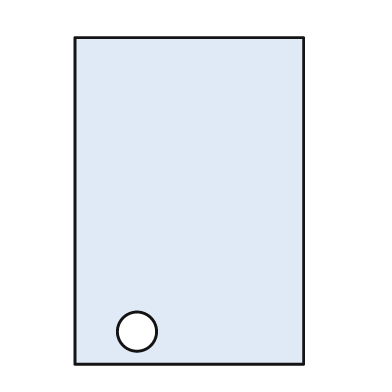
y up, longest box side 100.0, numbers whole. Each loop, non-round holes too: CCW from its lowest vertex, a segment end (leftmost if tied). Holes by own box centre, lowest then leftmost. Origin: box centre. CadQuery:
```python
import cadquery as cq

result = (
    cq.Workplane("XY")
    .moveTo(-35.0, -50.0)
    .lineTo(35.0, -50.0)
    .lineTo(35.0, 50.0)
    .lineTo(-35.0, 50.0)
    .close()
    .moveTo(-16.0, -40.0)
    .circle(6.0)
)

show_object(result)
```